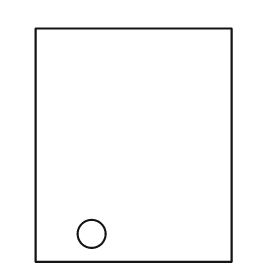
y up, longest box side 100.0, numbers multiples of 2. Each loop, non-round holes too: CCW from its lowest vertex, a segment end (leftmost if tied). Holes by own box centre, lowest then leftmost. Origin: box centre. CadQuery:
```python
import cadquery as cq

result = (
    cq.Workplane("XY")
    .moveTo(-42.0, -50.0)
    .lineTo(42.0, -50.0)
    .lineTo(42.0, 50.0)
    .lineTo(-42.0, 50.0)
    .close()
    .moveTo(-18.0, -38.0)
    .circle(6.0)
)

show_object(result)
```